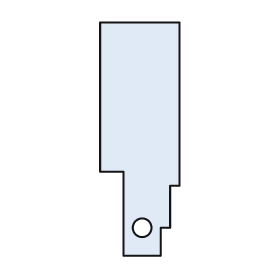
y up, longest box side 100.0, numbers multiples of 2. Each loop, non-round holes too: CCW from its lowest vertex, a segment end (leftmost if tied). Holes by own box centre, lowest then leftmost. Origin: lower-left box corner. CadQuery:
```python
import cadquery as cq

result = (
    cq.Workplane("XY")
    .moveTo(10.0, 0.0)
    .lineTo(26.0, 0.0)
    .lineTo(26.0, 12.0)
    .lineTo(30.0, 12.0)
    .lineTo(30.0, 30.0)
    .lineTo(34.0, 30.0)
    .lineTo(34.0, 100.0)
    .lineTo(0.0, 100.0)
    .lineTo(0.0, 36.0)
    .lineTo(10.0, 36.0)
    .close()
    .moveTo(18.0, 12.0)
    .circle(4.0)
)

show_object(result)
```